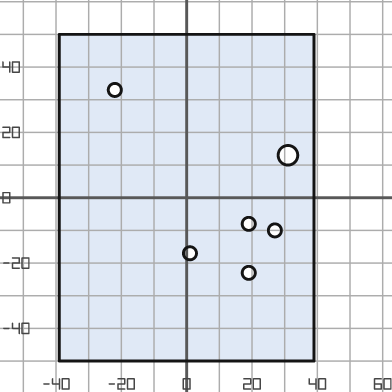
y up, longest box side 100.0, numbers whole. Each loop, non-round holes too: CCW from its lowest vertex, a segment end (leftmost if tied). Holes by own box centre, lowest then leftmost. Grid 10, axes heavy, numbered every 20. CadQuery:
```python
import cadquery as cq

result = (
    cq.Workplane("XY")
    .moveTo(-39.0, -50.0)
    .lineTo(39.0, -50.0)
    .lineTo(39.0, 50.0)
    .lineTo(-39.0, 50.0)
    .close()
    .moveTo(19.0, -23.0)
    .circle(2.0)
    .moveTo(1.0, -17.0)
    .circle(2.0)
    .moveTo(27.0, -10.0)
    .circle(2.0)
    .moveTo(19.0, -8.0)
    .circle(2.0)
    .moveTo(31.0, 13.0)
    .circle(3.0)
    .moveTo(-22.0, 33.0)
    .circle(2.0)
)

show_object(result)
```